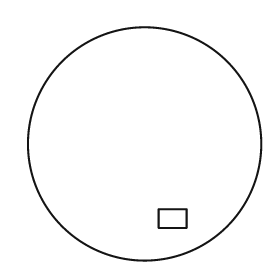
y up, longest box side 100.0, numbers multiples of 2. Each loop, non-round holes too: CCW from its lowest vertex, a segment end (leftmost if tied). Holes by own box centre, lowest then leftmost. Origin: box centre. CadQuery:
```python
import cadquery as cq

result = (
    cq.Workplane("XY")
    .moveTo(0.0, 0.0)
    .circle(50.0)
    .moveTo(6.0, -36.0)
    .lineTo(18.0, -36.0)
    .lineTo(18.0, -28.0)
    .lineTo(6.0, -28.0)
    .close()
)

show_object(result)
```